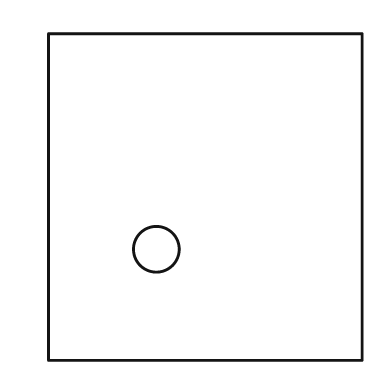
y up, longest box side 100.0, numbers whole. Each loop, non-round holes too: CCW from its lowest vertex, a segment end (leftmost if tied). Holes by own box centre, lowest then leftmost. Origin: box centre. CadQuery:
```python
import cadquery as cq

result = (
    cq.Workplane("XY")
    .moveTo(-48.0, -50.0)
    .lineTo(48.0, -50.0)
    .lineTo(48.0, 50.0)
    .lineTo(-48.0, 50.0)
    .close()
    .moveTo(-15.0, -16.0)
    .circle(7.0)
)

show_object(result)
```